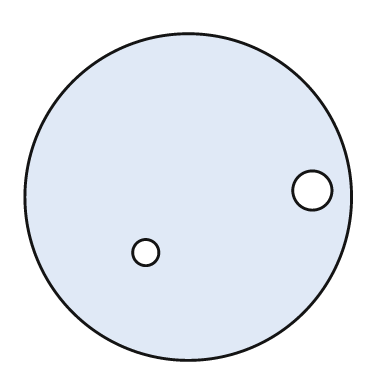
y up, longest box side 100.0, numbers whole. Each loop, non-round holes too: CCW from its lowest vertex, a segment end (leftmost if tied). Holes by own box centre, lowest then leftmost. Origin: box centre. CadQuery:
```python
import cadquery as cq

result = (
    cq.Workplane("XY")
    .moveTo(0.0, 0.0)
    .circle(50.0)
    .moveTo(-13.0, -17.0)
    .circle(4.0)
    .moveTo(38.0, 2.0)
    .circle(6.0)
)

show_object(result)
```